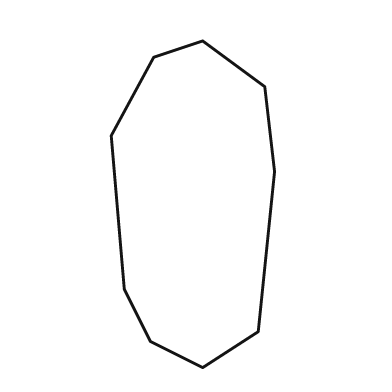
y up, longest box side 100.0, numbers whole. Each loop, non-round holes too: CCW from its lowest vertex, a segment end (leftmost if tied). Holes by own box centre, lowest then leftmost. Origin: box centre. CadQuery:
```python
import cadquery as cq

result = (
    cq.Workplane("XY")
    .moveTo(3.0, -50.0)
    .lineTo(20.0, -39.0)
    .lineTo(25.0, 10.0)
    .lineTo(22.0, 36.0)
    .lineTo(3.0, 50.0)
    .lineTo(-12.0, 45.0)
    .lineTo(-25.0, 21.0)
    .lineTo(-21.0, -26.0)
    .lineTo(-13.0, -42.0)
    .close()
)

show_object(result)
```